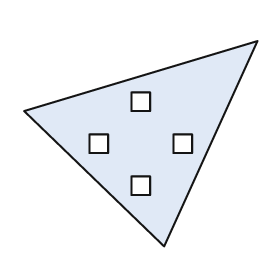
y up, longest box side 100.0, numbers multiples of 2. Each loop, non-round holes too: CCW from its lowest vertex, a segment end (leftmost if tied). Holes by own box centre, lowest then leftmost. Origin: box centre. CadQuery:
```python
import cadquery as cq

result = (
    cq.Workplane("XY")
    .moveTo(10.0, -44.0)
    .lineTo(50.0, 44.0)
    .lineTo(-50.0, 14.0)
    .close()
    .moveTo(-4.0, -22.0)
    .lineTo(4.0, -22.0)
    .lineTo(4.0, -14.0)
    .lineTo(-4.0, -14.0)
    .close()
    .moveTo(-22.0, -4.0)
    .lineTo(-14.0, -4.0)
    .lineTo(-14.0, 4.0)
    .lineTo(-22.0, 4.0)
    .close()
    .moveTo(14.0, -4.0)
    .lineTo(22.0, -4.0)
    .lineTo(22.0, 4.0)
    .lineTo(14.0, 4.0)
    .close()
    .moveTo(-4.0, 14.0)
    .lineTo(4.0, 14.0)
    .lineTo(4.0, 22.0)
    .lineTo(-4.0, 22.0)
    .close()
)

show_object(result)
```